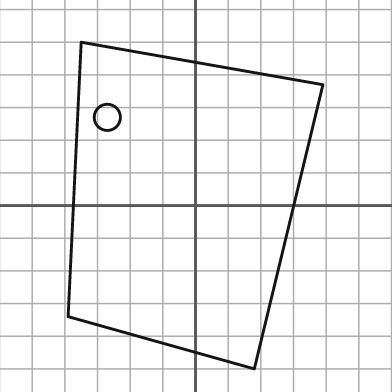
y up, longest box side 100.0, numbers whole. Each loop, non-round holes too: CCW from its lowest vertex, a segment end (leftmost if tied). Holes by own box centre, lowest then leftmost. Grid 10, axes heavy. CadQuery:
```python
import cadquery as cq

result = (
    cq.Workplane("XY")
    .moveTo(18.0, -50.0)
    .lineTo(39.0, 37.0)
    .lineTo(-35.0, 50.0)
    .lineTo(-39.0, -34.0)
    .close()
    .moveTo(-27.0, 27.0)
    .circle(4.0)
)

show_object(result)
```